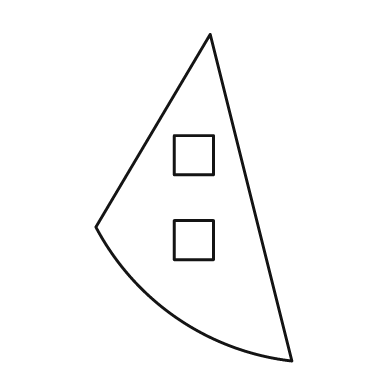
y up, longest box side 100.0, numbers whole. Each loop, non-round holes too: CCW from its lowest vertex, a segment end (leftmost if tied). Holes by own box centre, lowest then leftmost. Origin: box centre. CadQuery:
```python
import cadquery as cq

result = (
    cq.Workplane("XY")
    .moveTo(30.0, -50.0)
    .lineTo(5.0, 50.0)
    .lineTo(-30.0, -9.0)
    .threePointArc((-5.0, -37.0), (30.0, -50.0))
    .close()
    .moveTo(-6.0, -19.0)
    .lineTo(6.0, -19.0)
    .lineTo(6.0, -7.0)
    .lineTo(-6.0, -7.0)
    .close()
    .moveTo(-6.0, 7.0)
    .lineTo(6.0, 7.0)
    .lineTo(6.0, 19.0)
    .lineTo(-6.0, 19.0)
    .close()
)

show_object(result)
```